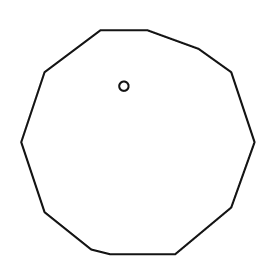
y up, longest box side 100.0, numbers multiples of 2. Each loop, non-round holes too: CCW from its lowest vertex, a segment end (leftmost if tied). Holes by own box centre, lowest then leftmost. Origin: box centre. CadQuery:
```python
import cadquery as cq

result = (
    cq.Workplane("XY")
    .moveTo(-12.0, -48.0)
    .lineTo(16.0, -48.0)
    .lineTo(40.0, -28.0)
    .lineTo(50.0, 0.0)
    .lineTo(40.0, 30.0)
    .lineTo(26.0, 40.0)
    .lineTo(4.0, 48.0)
    .lineTo(-16.0, 48.0)
    .lineTo(-40.0, 30.0)
    .lineTo(-50.0, 0.0)
    .lineTo(-40.0, -30.0)
    .lineTo(-20.0, -46.0)
    .close()
    .moveTo(-6.0, 24.0)
    .circle(2.0)
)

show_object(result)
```